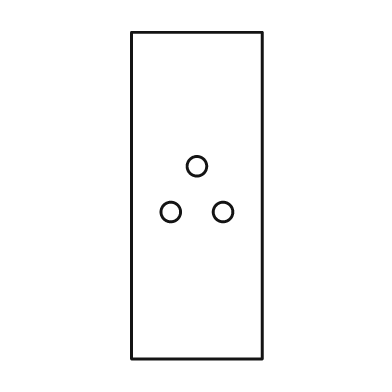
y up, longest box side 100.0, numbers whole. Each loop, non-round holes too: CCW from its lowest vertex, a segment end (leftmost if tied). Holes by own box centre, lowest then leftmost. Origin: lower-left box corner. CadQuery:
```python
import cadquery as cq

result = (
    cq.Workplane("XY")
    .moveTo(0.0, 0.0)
    .lineTo(40.0, 0.0)
    .lineTo(40.0, 100.0)
    .lineTo(0.0, 100.0)
    .close()
    .moveTo(12.0, 45.0)
    .circle(3.0)
    .moveTo(28.0, 45.0)
    .circle(3.0)
    .moveTo(20.0, 59.0)
    .circle(3.0)
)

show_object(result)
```